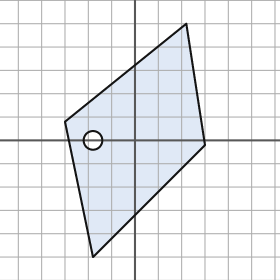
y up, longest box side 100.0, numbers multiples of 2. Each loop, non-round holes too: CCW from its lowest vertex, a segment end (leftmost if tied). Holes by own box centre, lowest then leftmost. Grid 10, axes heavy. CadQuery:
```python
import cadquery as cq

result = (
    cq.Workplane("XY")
    .moveTo(-18.0, -50.0)
    .lineTo(30.0, -2.0)
    .lineTo(22.0, 50.0)
    .lineTo(-30.0, 8.0)
    .close()
    .moveTo(-18.0, 0.0)
    .circle(4.0)
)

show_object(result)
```